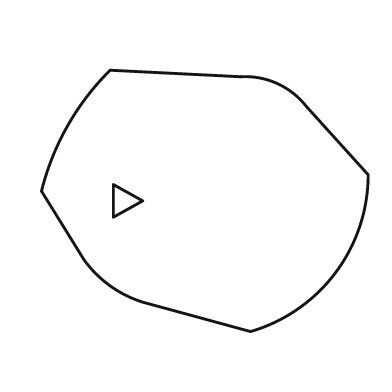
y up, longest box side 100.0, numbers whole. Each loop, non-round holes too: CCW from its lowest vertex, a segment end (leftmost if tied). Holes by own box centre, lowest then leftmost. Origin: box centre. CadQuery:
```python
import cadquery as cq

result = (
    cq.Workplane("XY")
    .moveTo(14.0, -40.0)
    .threePointArc((40.0, -22.0), (50.0, 8.0))
    .lineTo(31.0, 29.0)
    .threePointArc((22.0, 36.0), (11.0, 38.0))
    .lineTo(-29.0, 40.0)
    .threePointArc((-42.0, 23.0), (-50.0, 3.0))
    .lineTo(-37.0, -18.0)
    .threePointArc((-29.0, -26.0), (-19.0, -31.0))
    .close()
    .moveTo(-28.0, -5.0)
    .lineTo(-19.0, 0.0)
    .lineTo(-28.0, 5.0)
    .close()
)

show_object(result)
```